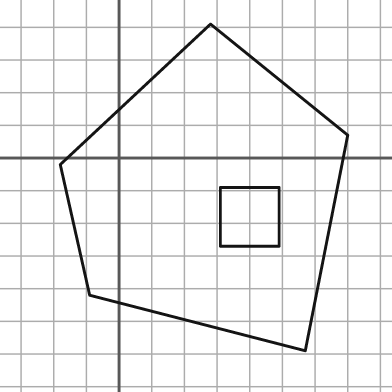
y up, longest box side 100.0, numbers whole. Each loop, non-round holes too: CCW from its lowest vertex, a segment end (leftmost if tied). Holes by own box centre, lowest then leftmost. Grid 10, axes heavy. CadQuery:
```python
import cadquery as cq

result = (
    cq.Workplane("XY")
    .moveTo(57.0, -59.0)
    .lineTo(70.0, 7.0)
    .lineTo(28.0, 41.0)
    .lineTo(-18.0, -2.0)
    .lineTo(-9.0, -42.0)
    .close()
    .moveTo(31.0, -27.0)
    .lineTo(49.0, -27.0)
    .lineTo(49.0, -9.0)
    .lineTo(31.0, -9.0)
    .close()
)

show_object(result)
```